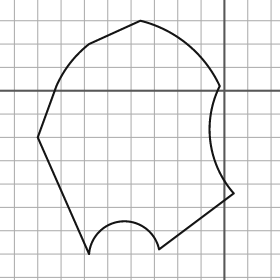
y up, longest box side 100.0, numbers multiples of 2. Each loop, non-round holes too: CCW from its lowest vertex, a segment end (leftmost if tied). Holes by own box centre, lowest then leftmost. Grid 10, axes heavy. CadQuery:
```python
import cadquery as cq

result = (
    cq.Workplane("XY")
    .moveTo(-58.0, -70.0)
    .threePointArc((-44.0, -56.0), (-28.0, -68.0))
    .lineTo(4.0, -44.0)
    .threePointArc((-6.0, -22.0), (-2.0, 2.0))
    .threePointArc((-16.0, 20.0), (-36.0, 30.0))
    .lineTo(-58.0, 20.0)
    .threePointArc((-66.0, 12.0), (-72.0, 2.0))
    .lineTo(-80.0, -20.0)
    .close()
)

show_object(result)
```